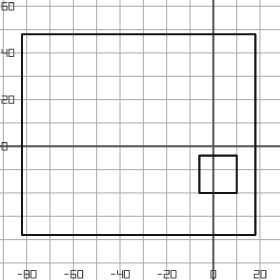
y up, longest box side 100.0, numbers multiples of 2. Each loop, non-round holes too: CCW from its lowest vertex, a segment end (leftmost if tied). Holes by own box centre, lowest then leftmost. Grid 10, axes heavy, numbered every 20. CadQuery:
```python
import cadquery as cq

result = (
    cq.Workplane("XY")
    .moveTo(-82.0, -38.0)
    .lineTo(18.0, -38.0)
    .lineTo(18.0, 48.0)
    .lineTo(-82.0, 48.0)
    .close()
    .moveTo(-6.0, -20.0)
    .lineTo(10.0, -20.0)
    .lineTo(10.0, -4.0)
    .lineTo(-6.0, -4.0)
    .close()
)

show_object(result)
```